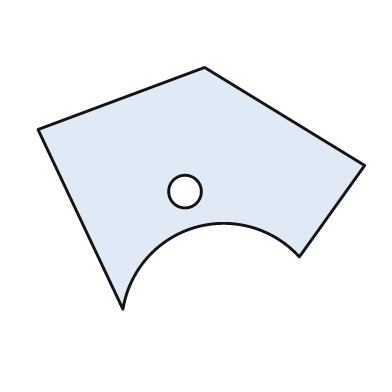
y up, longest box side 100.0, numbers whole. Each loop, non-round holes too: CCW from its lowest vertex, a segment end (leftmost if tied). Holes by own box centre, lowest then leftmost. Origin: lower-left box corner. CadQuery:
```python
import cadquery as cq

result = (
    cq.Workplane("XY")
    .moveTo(26.0, 0.0)
    .threePointArc((48.0, 25.0), (80.0, 16.0))
    .lineTo(100.0, 44.0)
    .lineTo(51.0, 74.0)
    .lineTo(0.0, 55.0)
    .close()
    .moveTo(45.0, 36.0)
    .circle(5.0)
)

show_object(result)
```